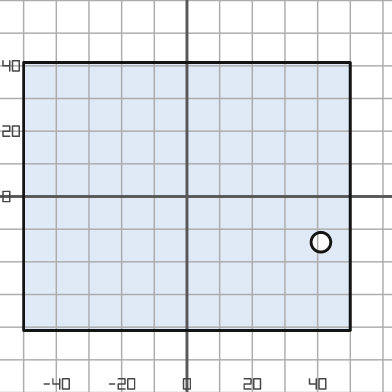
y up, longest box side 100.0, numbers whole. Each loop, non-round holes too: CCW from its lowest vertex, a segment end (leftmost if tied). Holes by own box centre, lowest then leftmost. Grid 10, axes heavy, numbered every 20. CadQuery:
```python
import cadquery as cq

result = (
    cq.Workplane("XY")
    .moveTo(-50.0, -41.0)
    .lineTo(50.0, -41.0)
    .lineTo(50.0, 41.0)
    .lineTo(-50.0, 41.0)
    .close()
    .moveTo(41.0, -14.0)
    .circle(3.0)
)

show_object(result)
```